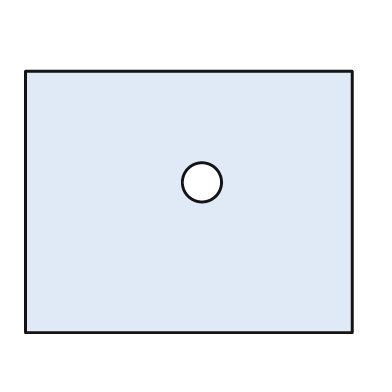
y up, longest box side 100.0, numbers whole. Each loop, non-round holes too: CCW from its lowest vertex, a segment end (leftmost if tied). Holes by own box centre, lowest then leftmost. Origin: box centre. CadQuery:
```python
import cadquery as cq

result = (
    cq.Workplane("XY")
    .moveTo(-50.0, -40.0)
    .lineTo(50.0, -40.0)
    .lineTo(50.0, 40.0)
    .lineTo(-50.0, 40.0)
    .close()
    .moveTo(4.0, 6.0)
    .circle(6.0)
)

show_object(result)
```